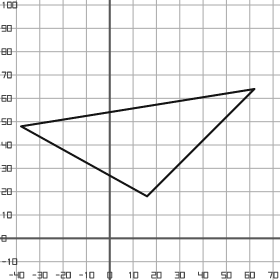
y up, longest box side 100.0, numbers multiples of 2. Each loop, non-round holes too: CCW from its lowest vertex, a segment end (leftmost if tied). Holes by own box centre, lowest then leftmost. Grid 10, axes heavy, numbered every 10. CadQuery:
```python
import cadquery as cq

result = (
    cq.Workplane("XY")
    .moveTo(16.0, 18.0)
    .lineTo(62.0, 64.0)
    .lineTo(-38.0, 48.0)
    .close()
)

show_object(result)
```